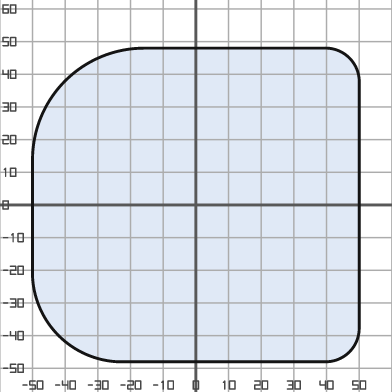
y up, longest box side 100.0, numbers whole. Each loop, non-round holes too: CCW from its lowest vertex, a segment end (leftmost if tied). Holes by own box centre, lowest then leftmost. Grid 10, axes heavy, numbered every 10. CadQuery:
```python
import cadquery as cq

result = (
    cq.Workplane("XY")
    .moveTo(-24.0, -48.0)
    .lineTo(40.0, -48.0)
    .threePointArc((47.0, -45.0), (50.0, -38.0))
    .lineTo(50.0, 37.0)
    .threePointArc((47.0, 45.0), (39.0, 48.0))
    .lineTo(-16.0, 48.0)
    .threePointArc((-40.0, 38.0), (-50.0, 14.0))
    .lineTo(-50.0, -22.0)
    .threePointArc((-42.0, -40.0), (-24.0, -48.0))
    .close()
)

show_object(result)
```